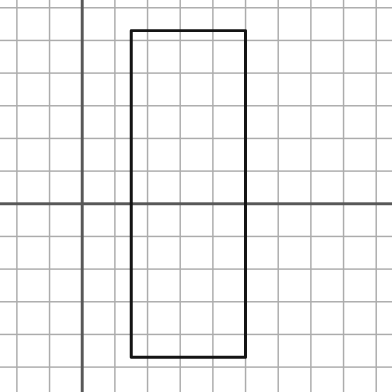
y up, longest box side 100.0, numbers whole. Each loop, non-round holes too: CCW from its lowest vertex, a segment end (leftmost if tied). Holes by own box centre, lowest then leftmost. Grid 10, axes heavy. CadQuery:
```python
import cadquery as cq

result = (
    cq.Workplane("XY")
    .moveTo(15.0, -47.0)
    .lineTo(50.0, -47.0)
    .lineTo(50.0, 53.0)
    .lineTo(15.0, 53.0)
    .close()
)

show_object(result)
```